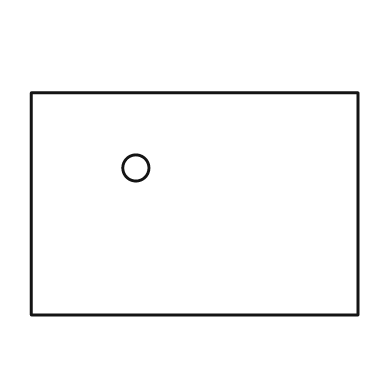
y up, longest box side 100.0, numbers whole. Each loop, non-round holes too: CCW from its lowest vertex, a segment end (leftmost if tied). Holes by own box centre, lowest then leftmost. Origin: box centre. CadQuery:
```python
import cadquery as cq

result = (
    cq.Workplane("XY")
    .moveTo(-50.0, -34.0)
    .lineTo(50.0, -34.0)
    .lineTo(50.0, 34.0)
    .lineTo(-50.0, 34.0)
    .close()
    .moveTo(-18.0, 11.0)
    .circle(4.0)
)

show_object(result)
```